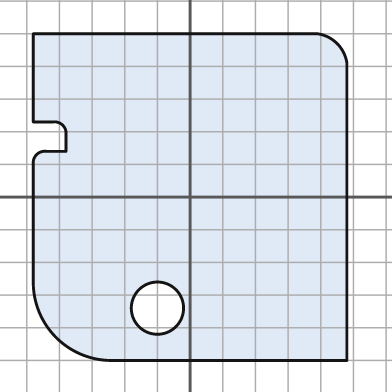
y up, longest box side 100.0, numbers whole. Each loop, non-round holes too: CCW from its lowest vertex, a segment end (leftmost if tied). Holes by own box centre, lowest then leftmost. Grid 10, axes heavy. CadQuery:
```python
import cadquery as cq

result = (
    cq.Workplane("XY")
    .moveTo(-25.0, -50.0)
    .lineTo(48.0, -50.0)
    .lineTo(48.0, 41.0)
    .threePointArc((45.0, 47.0), (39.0, 50.0))
    .lineTo(-48.0, 50.0)
    .lineTo(-48.0, 23.0)
    .lineTo(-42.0, 23.0)
    .threePointArc((-39.0, 22.0), (-38.0, 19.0))
    .lineTo(-38.0, 14.0)
    .lineTo(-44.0, 14.0)
    .threePointArc((-47.0, 13.0), (-48.0, 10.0))
    .lineTo(-48.0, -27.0)
    .threePointArc((-41.0, -43.0), (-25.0, -50.0))
    .close()
    .moveTo(-10.0, -34.0)
    .circle(8.0)
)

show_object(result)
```